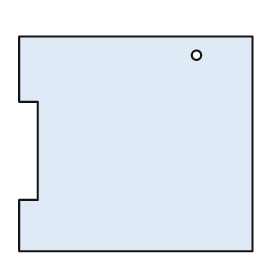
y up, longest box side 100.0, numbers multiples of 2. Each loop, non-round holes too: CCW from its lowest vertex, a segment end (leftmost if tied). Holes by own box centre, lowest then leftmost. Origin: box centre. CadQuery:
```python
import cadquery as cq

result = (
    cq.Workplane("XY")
    .moveTo(-50.0, -46.0)
    .lineTo(50.0, -46.0)
    .lineTo(50.0, 46.0)
    .lineTo(-50.0, 46.0)
    .lineTo(-50.0, 18.0)
    .lineTo(-42.0, 18.0)
    .lineTo(-42.0, -24.0)
    .lineTo(-50.0, -24.0)
    .close()
    .moveTo(26.0, 38.0)
    .circle(2.0)
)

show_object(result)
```